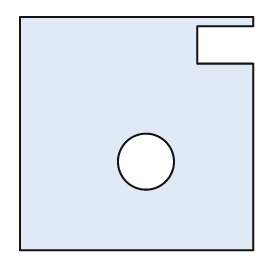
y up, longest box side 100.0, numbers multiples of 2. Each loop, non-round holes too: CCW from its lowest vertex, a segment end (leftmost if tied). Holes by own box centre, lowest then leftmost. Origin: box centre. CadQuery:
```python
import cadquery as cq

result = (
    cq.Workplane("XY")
    .moveTo(-50.0, -50.0)
    .lineTo(50.0, -50.0)
    .lineTo(50.0, 30.0)
    .lineTo(26.0, 30.0)
    .lineTo(26.0, 46.0)
    .lineTo(50.0, 46.0)
    .lineTo(50.0, 50.0)
    .lineTo(-50.0, 50.0)
    .close()
    .moveTo(4.0, -12.0)
    .circle(12.0)
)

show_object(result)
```